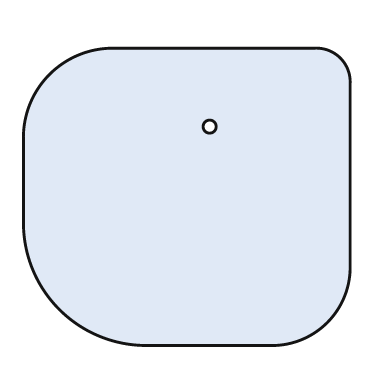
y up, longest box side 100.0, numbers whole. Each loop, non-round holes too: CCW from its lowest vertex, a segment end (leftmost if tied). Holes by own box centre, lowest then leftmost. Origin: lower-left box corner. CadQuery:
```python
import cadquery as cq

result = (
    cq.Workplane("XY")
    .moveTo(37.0, 0.0)
    .lineTo(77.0, 0.0)
    .threePointArc((93.0, 7.0), (100.0, 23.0))
    .lineTo(100.0, 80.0)
    .threePointArc((97.0, 88.0), (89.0, 91.0))
    .lineTo(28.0, 91.0)
    .threePointArc((8.0, 83.0), (0.0, 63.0))
    .lineTo(0.0, 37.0)
    .threePointArc((11.0, 11.0), (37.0, 0.0))
    .close()
    .moveTo(57.0, 67.0)
    .circle(2.0)
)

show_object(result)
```